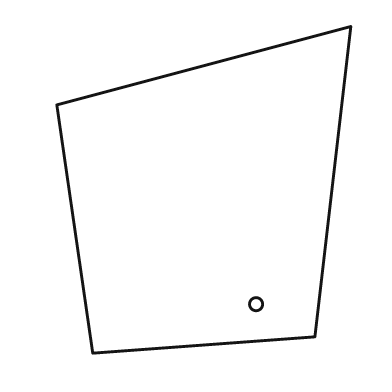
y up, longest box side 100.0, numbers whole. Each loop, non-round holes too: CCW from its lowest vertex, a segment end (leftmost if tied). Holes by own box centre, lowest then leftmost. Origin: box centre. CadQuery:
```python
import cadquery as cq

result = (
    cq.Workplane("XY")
    .moveTo(-34.0, -50.0)
    .lineTo(34.0, -45.0)
    .lineTo(45.0, 50.0)
    .lineTo(-45.0, 26.0)
    .close()
    .moveTo(16.0, -35.0)
    .circle(2.0)
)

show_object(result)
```